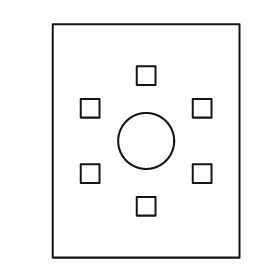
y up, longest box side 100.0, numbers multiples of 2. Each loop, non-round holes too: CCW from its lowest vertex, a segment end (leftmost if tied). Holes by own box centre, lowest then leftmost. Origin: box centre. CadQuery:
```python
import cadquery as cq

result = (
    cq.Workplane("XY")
    .moveTo(-40.0, -50.0)
    .lineTo(40.0, -50.0)
    .lineTo(40.0, 50.0)
    .lineTo(-40.0, 50.0)
    .close()
    .moveTo(-4.0, -32.0)
    .lineTo(4.0, -32.0)
    .lineTo(4.0, -24.0)
    .lineTo(-4.0, -24.0)
    .close()
    .moveTo(-28.0, -18.0)
    .lineTo(-20.0, -18.0)
    .lineTo(-20.0, -10.0)
    .lineTo(-28.0, -10.0)
    .close()
    .moveTo(20.0, -18.0)
    .lineTo(28.0, -18.0)
    .lineTo(28.0, -10.0)
    .lineTo(20.0, -10.0)
    .close()
    .moveTo(0.0, 0.0)
    .circle(12.0)
    .moveTo(-28.0, 10.0)
    .lineTo(-20.0, 10.0)
    .lineTo(-20.0, 18.0)
    .lineTo(-28.0, 18.0)
    .close()
    .moveTo(20.0, 10.0)
    .lineTo(28.0, 10.0)
    .lineTo(28.0, 18.0)
    .lineTo(20.0, 18.0)
    .close()
    .moveTo(-4.0, 24.0)
    .lineTo(4.0, 24.0)
    .lineTo(4.0, 32.0)
    .lineTo(-4.0, 32.0)
    .close()
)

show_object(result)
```